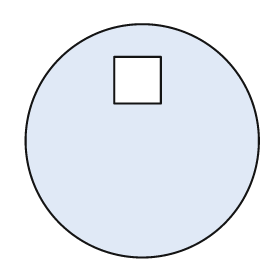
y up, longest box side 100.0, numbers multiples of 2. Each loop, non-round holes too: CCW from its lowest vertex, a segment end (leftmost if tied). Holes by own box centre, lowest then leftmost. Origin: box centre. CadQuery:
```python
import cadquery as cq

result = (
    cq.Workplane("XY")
    .moveTo(0.0, 0.0)
    .circle(50.0)
    .moveTo(-12.0, 16.0)
    .lineTo(8.0, 16.0)
    .lineTo(8.0, 36.0)
    .lineTo(-12.0, 36.0)
    .close()
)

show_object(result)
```